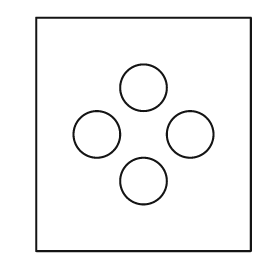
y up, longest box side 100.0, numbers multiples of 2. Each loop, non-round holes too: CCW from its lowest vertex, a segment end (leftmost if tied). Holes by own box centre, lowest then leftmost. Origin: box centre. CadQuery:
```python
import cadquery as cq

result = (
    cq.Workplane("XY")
    .moveTo(-46.0, -50.0)
    .lineTo(46.0, -50.0)
    .lineTo(46.0, 50.0)
    .lineTo(-46.0, 50.0)
    .close()
    .moveTo(0.0, -20.0)
    .circle(10.0)
    .moveTo(-20.0, 0.0)
    .circle(10.0)
    .moveTo(20.0, 0.0)
    .circle(10.0)
    .moveTo(0.0, 20.0)
    .circle(10.0)
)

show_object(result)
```